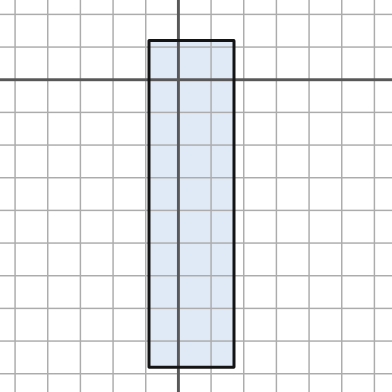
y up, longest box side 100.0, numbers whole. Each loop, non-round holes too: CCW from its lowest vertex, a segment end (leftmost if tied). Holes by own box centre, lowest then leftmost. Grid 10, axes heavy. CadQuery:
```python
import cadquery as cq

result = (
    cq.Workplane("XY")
    .moveTo(-9.0, -88.0)
    .lineTo(17.0, -88.0)
    .lineTo(17.0, 12.0)
    .lineTo(-9.0, 12.0)
    .close()
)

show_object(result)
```